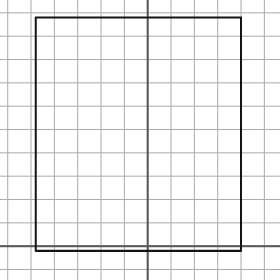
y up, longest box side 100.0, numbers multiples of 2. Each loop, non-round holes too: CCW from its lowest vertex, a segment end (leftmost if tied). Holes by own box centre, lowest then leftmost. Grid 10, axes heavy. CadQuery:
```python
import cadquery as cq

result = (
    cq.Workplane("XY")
    .moveTo(-48.0, -2.0)
    .lineTo(40.0, -2.0)
    .lineTo(40.0, 98.0)
    .lineTo(-48.0, 98.0)
    .close()
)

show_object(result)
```